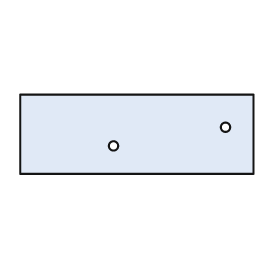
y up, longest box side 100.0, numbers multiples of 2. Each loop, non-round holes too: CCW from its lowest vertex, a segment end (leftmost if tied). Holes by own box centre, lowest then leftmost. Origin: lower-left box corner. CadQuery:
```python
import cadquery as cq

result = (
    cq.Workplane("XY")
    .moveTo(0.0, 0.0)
    .lineTo(100.0, 0.0)
    .lineTo(100.0, 34.0)
    .lineTo(0.0, 34.0)
    .close()
    .moveTo(40.0, 12.0)
    .circle(2.0)
    .moveTo(88.0, 20.0)
    .circle(2.0)
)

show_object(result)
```